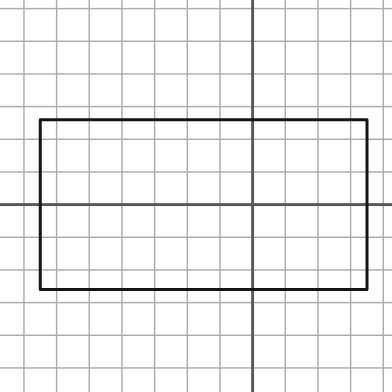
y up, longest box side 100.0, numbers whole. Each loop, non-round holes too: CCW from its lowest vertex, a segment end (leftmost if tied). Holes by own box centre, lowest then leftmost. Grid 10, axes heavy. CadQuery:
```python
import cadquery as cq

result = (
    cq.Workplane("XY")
    .moveTo(-65.0, -26.0)
    .lineTo(35.0, -26.0)
    .lineTo(35.0, 26.0)
    .lineTo(-65.0, 26.0)
    .close()
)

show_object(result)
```